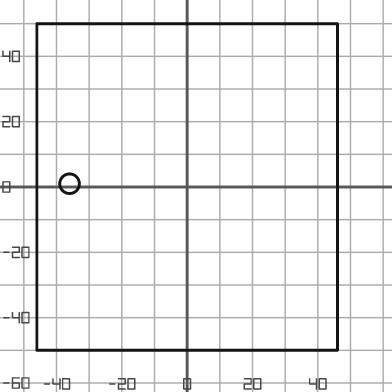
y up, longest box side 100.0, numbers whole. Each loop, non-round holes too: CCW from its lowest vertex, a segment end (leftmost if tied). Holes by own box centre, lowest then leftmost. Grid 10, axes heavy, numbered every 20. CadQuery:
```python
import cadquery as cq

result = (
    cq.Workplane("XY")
    .moveTo(-46.0, -50.0)
    .lineTo(46.0, -50.0)
    .lineTo(46.0, 50.0)
    .lineTo(-46.0, 50.0)
    .close()
    .moveTo(-36.0, 1.0)
    .circle(3.0)
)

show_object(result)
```